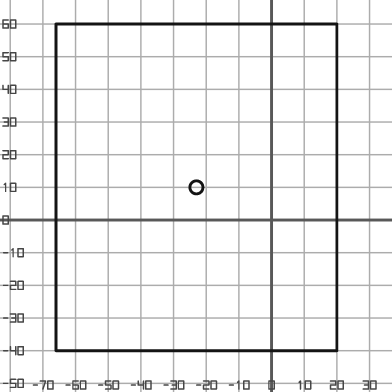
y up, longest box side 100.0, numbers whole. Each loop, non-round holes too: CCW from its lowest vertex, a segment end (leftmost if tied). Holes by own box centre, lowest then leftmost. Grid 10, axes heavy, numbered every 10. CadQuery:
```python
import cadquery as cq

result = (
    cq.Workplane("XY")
    .moveTo(-66.0, -40.0)
    .lineTo(20.0, -40.0)
    .lineTo(20.0, 60.0)
    .lineTo(-66.0, 60.0)
    .close()
    .moveTo(-23.0, 10.0)
    .circle(2.0)
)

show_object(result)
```